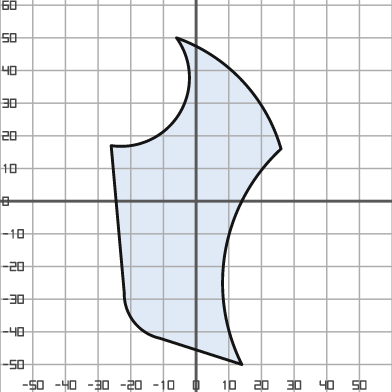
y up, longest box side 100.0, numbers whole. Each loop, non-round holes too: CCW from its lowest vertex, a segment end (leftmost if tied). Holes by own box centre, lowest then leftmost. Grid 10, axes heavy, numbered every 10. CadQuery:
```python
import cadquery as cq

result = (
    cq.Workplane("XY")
    .moveTo(14.0, -50.0)
    .threePointArc((9.0, -15.0), (26.0, 16.0))
    .threePointArc((14.0, 37.0), (-6.0, 50.0))
    .threePointArc((-5.0, 27.0), (-26.0, 17.0))
    .lineTo(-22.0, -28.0)
    .threePointArc((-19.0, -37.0), (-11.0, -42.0))
    .close()
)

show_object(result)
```